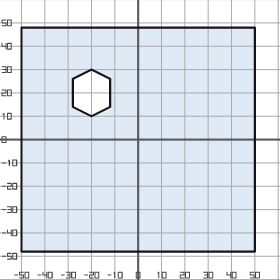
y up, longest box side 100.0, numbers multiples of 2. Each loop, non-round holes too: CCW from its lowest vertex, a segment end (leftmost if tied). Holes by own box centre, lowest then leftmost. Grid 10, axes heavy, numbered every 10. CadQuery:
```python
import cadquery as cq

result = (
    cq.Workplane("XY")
    .moveTo(-50.0, -48.0)
    .lineTo(50.0, -48.0)
    .lineTo(50.0, 48.0)
    .lineTo(-50.0, 48.0)
    .close()
    .moveTo(-20.0, 10.0)
    .lineTo(-12.0, 14.0)
    .lineTo(-12.0, 26.0)
    .lineTo(-20.0, 30.0)
    .lineTo(-28.0, 26.0)
    .lineTo(-28.0, 14.0)
    .close()
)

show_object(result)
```